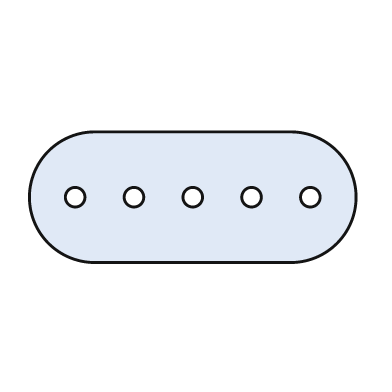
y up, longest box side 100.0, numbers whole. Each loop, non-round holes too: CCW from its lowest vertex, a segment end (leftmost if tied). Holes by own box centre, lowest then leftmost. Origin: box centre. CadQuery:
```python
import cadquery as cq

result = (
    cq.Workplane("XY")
    .moveTo(-30.0, -20.0)
    .lineTo(30.0, -20.0)
    .threePointArc((50.0, 0.0), (30.0, 20.0))
    .lineTo(-30.0, 20.0)
    .threePointArc((-50.0, 0.0), (-30.0, -20.0))
    .close()
    .moveTo(-36.0, 0.0)
    .circle(3.0)
    .moveTo(-18.0, 0.0)
    .circle(3.0)
    .moveTo(0.0, 0.0)
    .circle(3.0)
    .moveTo(18.0, 0.0)
    .circle(3.0)
    .moveTo(36.0, 0.0)
    .circle(3.0)
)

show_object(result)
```